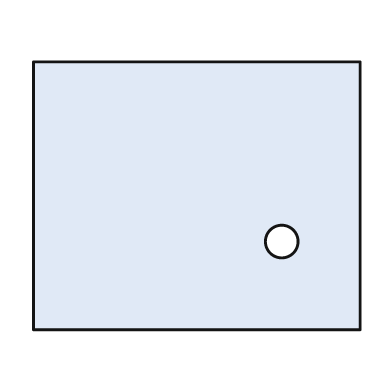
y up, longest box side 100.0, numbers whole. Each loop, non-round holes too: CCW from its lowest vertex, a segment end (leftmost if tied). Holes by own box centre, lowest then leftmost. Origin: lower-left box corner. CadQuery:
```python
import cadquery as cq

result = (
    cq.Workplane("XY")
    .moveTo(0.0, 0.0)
    .lineTo(100.0, 0.0)
    .lineTo(100.0, 82.0)
    .lineTo(0.0, 82.0)
    .close()
    .moveTo(76.0, 27.0)
    .circle(5.0)
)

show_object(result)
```